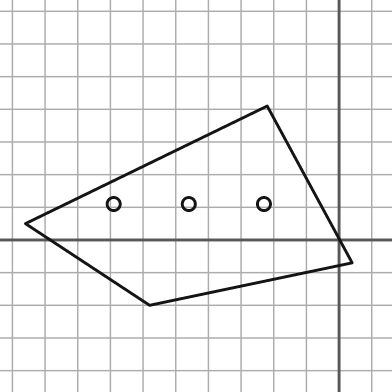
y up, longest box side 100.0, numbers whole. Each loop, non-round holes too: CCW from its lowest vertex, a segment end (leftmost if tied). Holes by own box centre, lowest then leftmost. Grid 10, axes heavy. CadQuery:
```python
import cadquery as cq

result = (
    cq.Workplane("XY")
    .moveTo(-58.0, -20.0)
    .lineTo(4.0, -7.0)
    .lineTo(-22.0, 41.0)
    .lineTo(-96.0, 5.0)
    .close()
    .moveTo(-69.0, 11.0)
    .circle(2.0)
    .moveTo(-46.0, 11.0)
    .circle(2.0)
    .moveTo(-23.0, 11.0)
    .circle(2.0)
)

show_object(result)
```